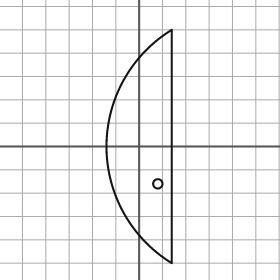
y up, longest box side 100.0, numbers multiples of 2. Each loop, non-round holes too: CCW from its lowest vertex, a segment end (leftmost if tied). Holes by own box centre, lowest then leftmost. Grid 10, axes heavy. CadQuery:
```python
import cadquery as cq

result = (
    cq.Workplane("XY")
    .moveTo(14.0, -50.0)
    .lineTo(14.0, 50.0)
    .threePointArc((-14.0, 0.0), (14.0, -50.0))
    .close()
    .moveTo(8.0, -16.0)
    .circle(2.0)
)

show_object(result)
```